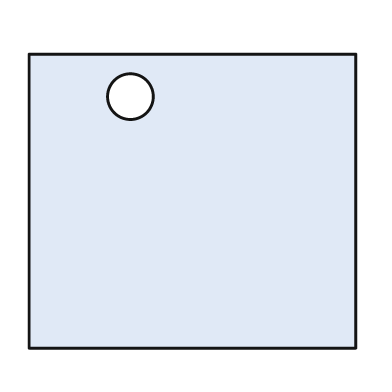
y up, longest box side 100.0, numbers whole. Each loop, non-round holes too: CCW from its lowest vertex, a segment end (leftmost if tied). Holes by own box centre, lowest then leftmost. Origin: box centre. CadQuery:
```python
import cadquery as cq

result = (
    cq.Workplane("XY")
    .moveTo(-50.0, -45.0)
    .lineTo(50.0, -45.0)
    .lineTo(50.0, 45.0)
    .lineTo(-50.0, 45.0)
    .close()
    .moveTo(-19.0, 32.0)
    .circle(7.0)
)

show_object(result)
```